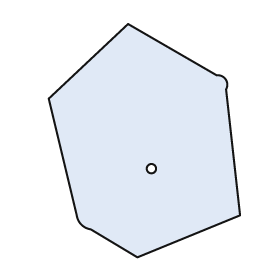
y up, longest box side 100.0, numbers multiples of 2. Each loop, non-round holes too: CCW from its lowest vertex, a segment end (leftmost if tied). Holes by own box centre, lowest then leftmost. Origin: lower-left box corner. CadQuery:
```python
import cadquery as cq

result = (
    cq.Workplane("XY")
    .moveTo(38.0, 0.0)
    .lineTo(82.0, 18.0)
    .lineTo(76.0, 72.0)
    .threePointArc((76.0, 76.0), (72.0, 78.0))
    .lineTo(34.0, 100.0)
    .lineTo(0.0, 68.0)
    .lineTo(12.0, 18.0)
    .threePointArc((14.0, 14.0), (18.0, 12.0))
    .close()
    .moveTo(44.0, 38.0)
    .circle(2.0)
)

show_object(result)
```